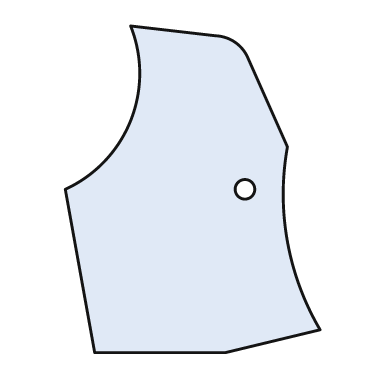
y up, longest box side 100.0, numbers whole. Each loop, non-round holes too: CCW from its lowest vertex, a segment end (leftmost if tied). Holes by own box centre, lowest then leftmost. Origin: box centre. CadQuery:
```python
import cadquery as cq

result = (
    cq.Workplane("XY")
    .moveTo(-30.0, -50.0)
    .lineTo(10.0, -50.0)
    .lineTo(39.0, -43.0)
    .threePointArc((29.0, -16.0), (29.0, 13.0))
    .lineTo(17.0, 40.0)
    .threePointArc((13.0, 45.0), (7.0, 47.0))
    .lineTo(-19.0, 50.0)
    .threePointArc((-19.0, 21.0), (-39.0, 0.0))
    .close()
    .moveTo(16.0, 0.0)
    .circle(3.0)
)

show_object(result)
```